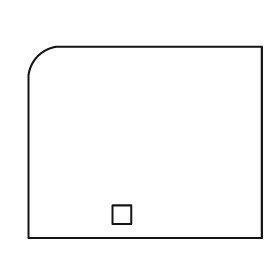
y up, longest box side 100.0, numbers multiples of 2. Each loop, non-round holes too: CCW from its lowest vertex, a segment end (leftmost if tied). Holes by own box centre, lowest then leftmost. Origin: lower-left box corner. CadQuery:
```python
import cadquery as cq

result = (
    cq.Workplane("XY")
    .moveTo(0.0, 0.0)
    .lineTo(100.0, 0.0)
    .lineTo(100.0, 82.0)
    .lineTo(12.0, 82.0)
    .threePointArc((4.0, 78.0), (0.0, 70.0))
    .close()
    .moveTo(36.0, 6.0)
    .lineTo(44.0, 6.0)
    .lineTo(44.0, 14.0)
    .lineTo(36.0, 14.0)
    .close()
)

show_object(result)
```